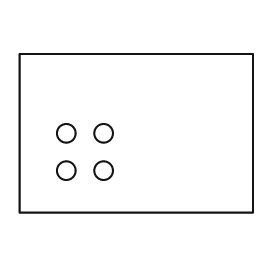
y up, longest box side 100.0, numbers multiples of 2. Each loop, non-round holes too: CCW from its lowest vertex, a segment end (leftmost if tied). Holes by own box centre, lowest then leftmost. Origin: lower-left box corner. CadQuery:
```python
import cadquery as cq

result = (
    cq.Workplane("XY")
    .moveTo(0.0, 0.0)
    .lineTo(100.0, 0.0)
    .lineTo(100.0, 68.0)
    .lineTo(0.0, 68.0)
    .close()
    .moveTo(20.0, 18.0)
    .circle(4.0)
    .moveTo(36.0, 18.0)
    .circle(4.0)
    .moveTo(20.0, 34.0)
    .circle(4.0)
    .moveTo(36.0, 34.0)
    .circle(4.0)
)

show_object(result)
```